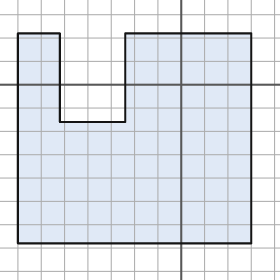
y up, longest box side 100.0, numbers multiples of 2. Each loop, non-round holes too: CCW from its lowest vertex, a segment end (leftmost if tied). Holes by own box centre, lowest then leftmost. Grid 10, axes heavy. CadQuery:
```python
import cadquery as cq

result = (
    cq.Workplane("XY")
    .moveTo(-70.0, -68.0)
    .lineTo(30.0, -68.0)
    .lineTo(30.0, 22.0)
    .lineTo(-24.0, 22.0)
    .lineTo(-24.0, -16.0)
    .lineTo(-52.0, -16.0)
    .lineTo(-52.0, 22.0)
    .lineTo(-70.0, 22.0)
    .close()
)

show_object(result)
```